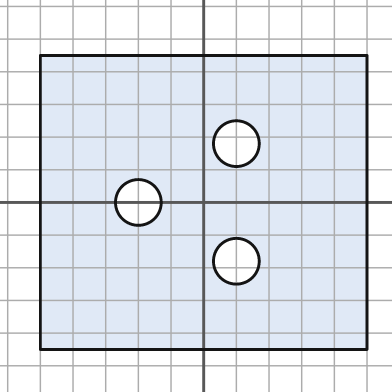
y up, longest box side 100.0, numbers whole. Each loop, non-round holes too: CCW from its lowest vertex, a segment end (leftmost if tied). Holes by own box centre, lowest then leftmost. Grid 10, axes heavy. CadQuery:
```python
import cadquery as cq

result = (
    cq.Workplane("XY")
    .moveTo(-50.0, -45.0)
    .lineTo(50.0, -45.0)
    .lineTo(50.0, 45.0)
    .lineTo(-50.0, 45.0)
    .close()
    .moveTo(10.0, -18.0)
    .circle(7.0)
    .moveTo(-20.0, 0.0)
    .circle(7.0)
    .moveTo(10.0, 18.0)
    .circle(7.0)
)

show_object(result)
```